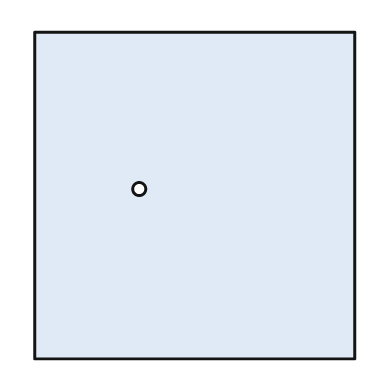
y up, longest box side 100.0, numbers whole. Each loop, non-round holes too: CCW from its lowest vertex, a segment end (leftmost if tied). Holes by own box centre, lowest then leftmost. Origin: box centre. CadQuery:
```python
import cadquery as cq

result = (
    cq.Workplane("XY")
    .moveTo(-49.0, -50.0)
    .lineTo(49.0, -50.0)
    .lineTo(49.0, 50.0)
    .lineTo(-49.0, 50.0)
    .close()
    .moveTo(-17.0, 2.0)
    .circle(2.0)
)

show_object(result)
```